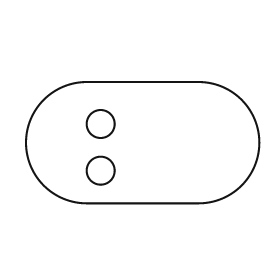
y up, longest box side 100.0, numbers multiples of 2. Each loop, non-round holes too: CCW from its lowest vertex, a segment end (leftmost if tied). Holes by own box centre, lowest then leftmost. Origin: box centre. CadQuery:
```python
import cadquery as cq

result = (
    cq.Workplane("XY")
    .moveTo(-24.0, -26.0)
    .lineTo(24.0, -26.0)
    .threePointArc((50.0, 0.0), (24.0, 26.0))
    .lineTo(-24.0, 26.0)
    .threePointArc((-50.0, 0.0), (-24.0, -26.0))
    .close()
    .moveTo(-18.0, -12.0)
    .circle(6.0)
    .moveTo(-18.0, 8.0)
    .circle(6.0)
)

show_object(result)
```